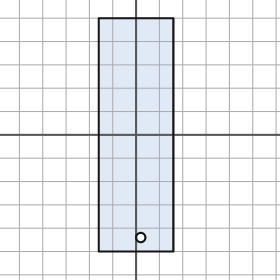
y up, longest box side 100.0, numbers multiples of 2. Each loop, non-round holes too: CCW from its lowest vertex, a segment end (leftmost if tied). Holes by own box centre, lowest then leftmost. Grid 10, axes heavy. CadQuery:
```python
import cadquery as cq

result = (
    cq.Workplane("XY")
    .moveTo(-16.0, -50.0)
    .lineTo(16.0, -50.0)
    .lineTo(16.0, 50.0)
    .lineTo(-16.0, 50.0)
    .close()
    .moveTo(2.0, -44.0)
    .circle(2.0)
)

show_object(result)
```